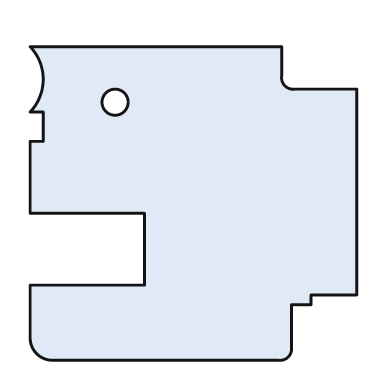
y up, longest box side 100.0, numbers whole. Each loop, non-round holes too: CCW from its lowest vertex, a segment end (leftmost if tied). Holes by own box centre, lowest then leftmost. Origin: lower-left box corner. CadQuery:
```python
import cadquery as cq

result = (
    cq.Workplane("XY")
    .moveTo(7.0, 0.0)
    .lineTo(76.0, 0.0)
    .threePointArc((79.0, 1.0), (80.0, 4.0))
    .lineTo(80.0, 17.0)
    .lineTo(86.0, 17.0)
    .lineTo(86.0, 20.0)
    .lineTo(100.0, 20.0)
    .lineTo(100.0, 83.0)
    .lineTo(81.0, 83.0)
    .threePointArc((78.0, 84.0), (77.0, 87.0))
    .lineTo(77.0, 96.0)
    .lineTo(0.0, 96.0)
    .threePointArc((4.0, 86.0), (0.0, 76.0))
    .lineTo(4.0, 76.0)
    .lineTo(4.0, 67.0)
    .lineTo(0.0, 67.0)
    .lineTo(0.0, 45.0)
    .lineTo(35.0, 45.0)
    .lineTo(35.0, 23.0)
    .lineTo(0.0, 23.0)
    .lineTo(0.0, 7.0)
    .threePointArc((2.0, 2.0), (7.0, 0.0))
    .close()
    .moveTo(26.0, 79.0)
    .circle(4.0)
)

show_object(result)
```